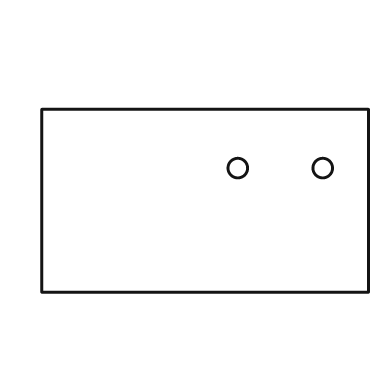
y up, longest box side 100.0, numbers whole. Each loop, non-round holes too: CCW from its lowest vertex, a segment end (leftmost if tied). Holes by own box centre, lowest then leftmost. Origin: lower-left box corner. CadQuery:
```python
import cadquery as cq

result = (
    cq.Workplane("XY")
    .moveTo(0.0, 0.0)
    .lineTo(100.0, 0.0)
    .lineTo(100.0, 56.0)
    .lineTo(0.0, 56.0)
    .close()
    .moveTo(60.0, 38.0)
    .circle(3.0)
    .moveTo(86.0, 38.0)
    .circle(3.0)
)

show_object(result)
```